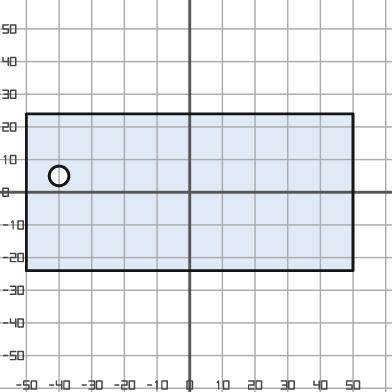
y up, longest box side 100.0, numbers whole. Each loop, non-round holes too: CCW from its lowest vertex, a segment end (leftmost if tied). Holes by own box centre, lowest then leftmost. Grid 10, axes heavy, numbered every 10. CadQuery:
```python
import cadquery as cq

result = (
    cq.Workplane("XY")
    .moveTo(-50.0, -24.0)
    .lineTo(50.0, -24.0)
    .lineTo(50.0, 24.0)
    .lineTo(-50.0, 24.0)
    .close()
    .moveTo(-40.0, 5.0)
    .circle(3.0)
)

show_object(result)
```